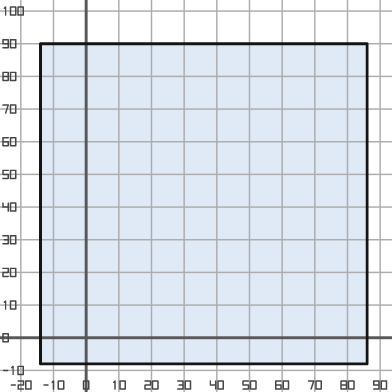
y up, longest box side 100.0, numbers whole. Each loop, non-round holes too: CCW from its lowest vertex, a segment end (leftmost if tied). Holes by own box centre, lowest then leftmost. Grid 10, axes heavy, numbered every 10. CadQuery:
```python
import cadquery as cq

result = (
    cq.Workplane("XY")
    .moveTo(-14.0, -8.0)
    .lineTo(86.0, -8.0)
    .lineTo(86.0, 90.0)
    .lineTo(-14.0, 90.0)
    .close()
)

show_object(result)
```